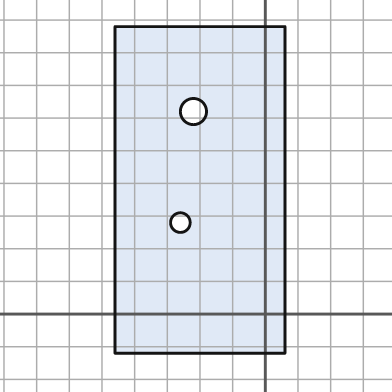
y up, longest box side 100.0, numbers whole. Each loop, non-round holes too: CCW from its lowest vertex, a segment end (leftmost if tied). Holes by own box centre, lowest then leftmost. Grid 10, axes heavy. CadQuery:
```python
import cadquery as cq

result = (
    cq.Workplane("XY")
    .moveTo(-46.0, -12.0)
    .lineTo(6.0, -12.0)
    .lineTo(6.0, 88.0)
    .lineTo(-46.0, 88.0)
    .close()
    .moveTo(-26.0, 28.0)
    .circle(3.0)
    .moveTo(-22.0, 62.0)
    .circle(4.0)
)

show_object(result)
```